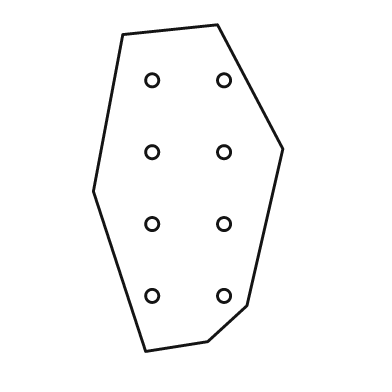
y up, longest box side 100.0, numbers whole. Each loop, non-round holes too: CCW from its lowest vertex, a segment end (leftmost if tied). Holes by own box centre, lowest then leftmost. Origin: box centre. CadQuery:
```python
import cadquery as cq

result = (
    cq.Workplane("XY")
    .moveTo(-13.0, -50.0)
    .lineTo(6.0, -47.0)
    .lineTo(18.0, -36.0)
    .lineTo(29.0, 12.0)
    .lineTo(9.0, 50.0)
    .lineTo(-20.0, 47.0)
    .lineTo(-29.0, -1.0)
    .close()
    .moveTo(-11.0, -33.0)
    .circle(2.0)
    .moveTo(11.0, -33.0)
    .circle(2.0)
    .moveTo(-11.0, -11.0)
    .circle(2.0)
    .moveTo(11.0, -11.0)
    .circle(2.0)
    .moveTo(-11.0, 11.0)
    .circle(2.0)
    .moveTo(11.0, 11.0)
    .circle(2.0)
    .moveTo(-11.0, 33.0)
    .circle(2.0)
    .moveTo(11.0, 33.0)
    .circle(2.0)
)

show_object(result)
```